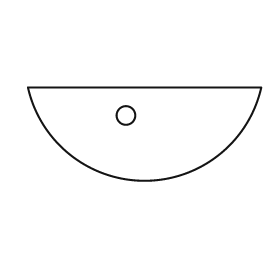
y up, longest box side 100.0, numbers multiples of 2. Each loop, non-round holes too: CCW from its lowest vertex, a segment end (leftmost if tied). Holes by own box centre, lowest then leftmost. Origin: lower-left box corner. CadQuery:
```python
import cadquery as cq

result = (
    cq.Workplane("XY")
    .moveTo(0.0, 40.0)
    .threePointArc((50.0, 0.0), (100.0, 40.0))
    .close()
    .moveTo(42.0, 28.0)
    .circle(4.0)
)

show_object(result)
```